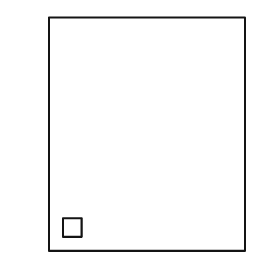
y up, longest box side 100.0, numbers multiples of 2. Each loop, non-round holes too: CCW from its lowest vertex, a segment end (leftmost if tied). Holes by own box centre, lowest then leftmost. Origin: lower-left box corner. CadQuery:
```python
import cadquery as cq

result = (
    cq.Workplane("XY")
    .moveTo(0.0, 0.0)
    .lineTo(84.0, 0.0)
    .lineTo(84.0, 100.0)
    .lineTo(0.0, 100.0)
    .close()
    .moveTo(6.0, 6.0)
    .lineTo(14.0, 6.0)
    .lineTo(14.0, 14.0)
    .lineTo(6.0, 14.0)
    .close()
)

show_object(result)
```